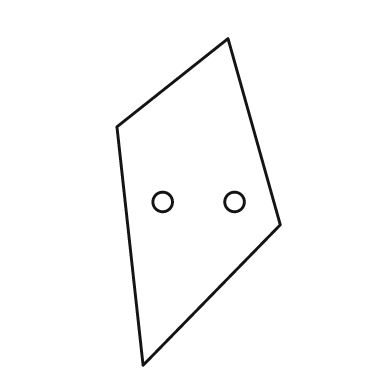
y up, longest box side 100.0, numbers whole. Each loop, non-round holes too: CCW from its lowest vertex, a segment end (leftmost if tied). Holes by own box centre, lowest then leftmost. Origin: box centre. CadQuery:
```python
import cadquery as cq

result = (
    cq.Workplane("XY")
    .moveTo(-17.0, -50.0)
    .lineTo(25.0, -7.0)
    .lineTo(9.0, 50.0)
    .lineTo(-25.0, 23.0)
    .close()
    .moveTo(-11.0, 0.0)
    .circle(3.0)
    .moveTo(11.0, 0.0)
    .circle(3.0)
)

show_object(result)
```